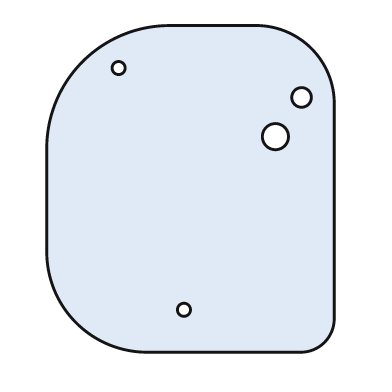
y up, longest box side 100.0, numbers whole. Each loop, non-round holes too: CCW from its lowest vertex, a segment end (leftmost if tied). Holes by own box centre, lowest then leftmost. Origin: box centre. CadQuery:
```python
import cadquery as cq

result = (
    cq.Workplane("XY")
    .moveTo(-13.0, -50.0)
    .lineTo(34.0, -50.0)
    .threePointArc((41.0, -47.0), (44.0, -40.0))
    .lineTo(44.0, 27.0)
    .threePointArc((37.0, 43.0), (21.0, 50.0))
    .lineTo(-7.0, 50.0)
    .threePointArc((-33.0, 39.0), (-44.0, 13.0))
    .lineTo(-44.0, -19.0)
    .threePointArc((-35.0, -41.0), (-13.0, -50.0))
    .close()
    .moveTo(-2.0, -37.0)
    .circle(2.0)
    .moveTo(26.0, 16.0)
    .circle(4.0)
    .moveTo(34.0, 28.0)
    .circle(3.0)
    .moveTo(-22.0, 37.0)
    .circle(2.0)
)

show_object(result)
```